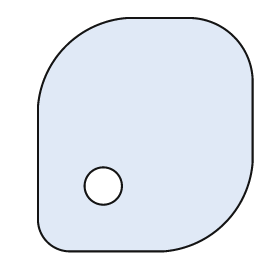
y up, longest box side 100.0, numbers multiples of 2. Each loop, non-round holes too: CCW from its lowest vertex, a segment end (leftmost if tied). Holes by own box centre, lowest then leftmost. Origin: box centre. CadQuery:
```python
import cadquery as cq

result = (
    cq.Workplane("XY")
    .moveTo(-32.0, -50.0)
    .lineTo(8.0, -50.0)
    .threePointArc((34.0, -38.0), (46.0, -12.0))
    .lineTo(46.0, 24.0)
    .threePointArc((38.0, 42.0), (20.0, 50.0))
    .lineTo(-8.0, 50.0)
    .threePointArc((-34.0, 38.0), (-46.0, 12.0))
    .lineTo(-46.0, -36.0)
    .threePointArc((-42.0, -46.0), (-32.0, -50.0))
    .close()
    .moveTo(-18.0, -22.0)
    .circle(8.0)
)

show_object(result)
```